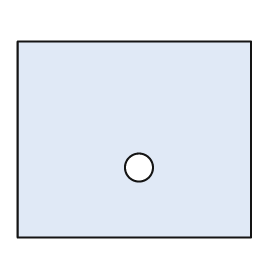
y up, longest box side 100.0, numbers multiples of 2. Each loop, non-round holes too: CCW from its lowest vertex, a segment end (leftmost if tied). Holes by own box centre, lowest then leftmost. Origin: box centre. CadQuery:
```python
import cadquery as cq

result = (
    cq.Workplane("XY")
    .moveTo(-50.0, -42.0)
    .lineTo(50.0, -42.0)
    .lineTo(50.0, 42.0)
    .lineTo(-50.0, 42.0)
    .close()
    .moveTo(2.0, -12.0)
    .circle(6.0)
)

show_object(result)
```